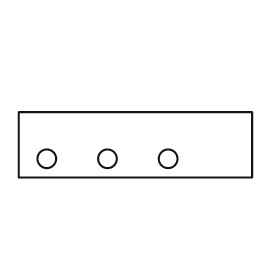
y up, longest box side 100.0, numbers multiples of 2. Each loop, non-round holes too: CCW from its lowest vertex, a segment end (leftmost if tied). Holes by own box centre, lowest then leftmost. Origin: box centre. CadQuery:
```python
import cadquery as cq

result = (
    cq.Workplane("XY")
    .moveTo(-50.0, -14.0)
    .lineTo(50.0, -14.0)
    .lineTo(50.0, 14.0)
    .lineTo(-50.0, 14.0)
    .close()
    .moveTo(-38.0, -6.0)
    .circle(4.0)
    .moveTo(-12.0, -6.0)
    .circle(4.0)
    .moveTo(14.0, -6.0)
    .circle(4.0)
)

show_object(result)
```